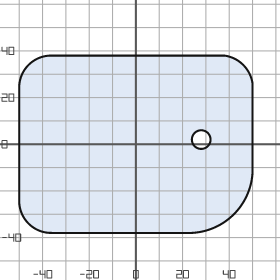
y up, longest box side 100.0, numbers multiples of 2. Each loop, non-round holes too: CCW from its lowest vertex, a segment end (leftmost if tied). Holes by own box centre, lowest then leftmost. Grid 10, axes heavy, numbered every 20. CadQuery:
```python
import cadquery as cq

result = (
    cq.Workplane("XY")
    .moveTo(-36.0, -38.0)
    .lineTo(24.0, -38.0)
    .threePointArc((42.0, -30.0), (50.0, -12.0))
    .lineTo(50.0, 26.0)
    .threePointArc((46.0, 34.0), (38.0, 38.0))
    .lineTo(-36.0, 38.0)
    .threePointArc((-46.0, 34.0), (-50.0, 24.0))
    .lineTo(-50.0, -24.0)
    .threePointArc((-46.0, -34.0), (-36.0, -38.0))
    .close()
    .moveTo(28.0, 2.0)
    .circle(4.0)
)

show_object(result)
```